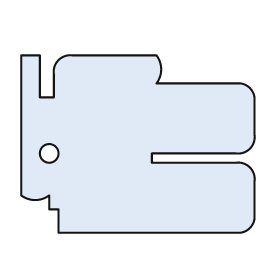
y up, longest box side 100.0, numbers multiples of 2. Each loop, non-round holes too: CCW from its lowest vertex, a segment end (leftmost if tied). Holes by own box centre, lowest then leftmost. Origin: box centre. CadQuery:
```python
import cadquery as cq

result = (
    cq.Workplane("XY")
    .moveTo(-34.0, -38.0)
    .lineTo(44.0, -38.0)
    .threePointArc((48.0, -36.0), (50.0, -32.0))
    .lineTo(50.0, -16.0)
    .threePointArc((48.0, -10.0), (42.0, -8.0))
    .lineTo(6.0, -8.0)
    .lineTo(6.0, -4.0)
    .lineTo(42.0, -4.0)
    .threePointArc((48.0, -2.0), (50.0, 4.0))
    .lineTo(50.0, 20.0)
    .threePointArc((48.0, 24.0), (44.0, 26.0))
    .lineTo(8.0, 26.0)
    .threePointArc((10.0, 32.0), (8.0, 38.0))
    .lineTo(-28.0, 38.0)
    .threePointArc((-34.0, 36.0), (-36.0, 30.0))
    .lineTo(-36.0, 20.0)
    .lineTo(-42.0, 20.0)
    .lineTo(-42.0, 38.0)
    .lineTo(-50.0, 38.0)
    .lineTo(-50.0, -22.0)
    .threePointArc((-44.0, -24.0), (-38.0, -22.0))
    .lineTo(-38.0, -28.0)
    .lineTo(-34.0, -28.0)
    .close()
    .moveTo(-38.0, -4.0)
    .circle(4.0)
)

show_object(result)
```